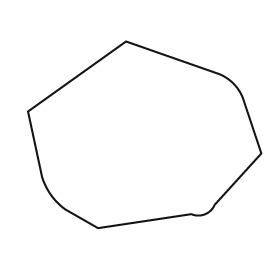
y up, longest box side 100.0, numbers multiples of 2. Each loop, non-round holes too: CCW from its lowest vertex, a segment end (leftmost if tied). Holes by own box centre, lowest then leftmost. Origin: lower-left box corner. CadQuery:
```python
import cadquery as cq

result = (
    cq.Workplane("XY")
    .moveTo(30.0, 0.0)
    .lineTo(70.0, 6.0)
    .threePointArc((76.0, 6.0), (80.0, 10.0))
    .lineTo(100.0, 32.0)
    .lineTo(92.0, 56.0)
    .threePointArc((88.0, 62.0), (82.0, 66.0))
    .lineTo(42.0, 80.0)
    .lineTo(0.0, 50.0)
    .lineTo(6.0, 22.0)
    .threePointArc((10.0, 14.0), (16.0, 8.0))
    .close()
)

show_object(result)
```